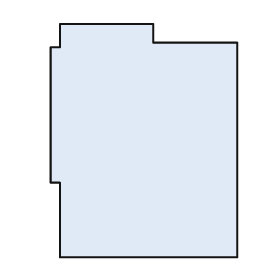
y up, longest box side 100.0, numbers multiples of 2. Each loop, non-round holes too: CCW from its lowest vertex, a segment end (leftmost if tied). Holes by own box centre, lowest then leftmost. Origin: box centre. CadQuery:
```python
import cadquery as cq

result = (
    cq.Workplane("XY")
    .moveTo(-36.0, -50.0)
    .lineTo(40.0, -50.0)
    .lineTo(40.0, 42.0)
    .lineTo(4.0, 42.0)
    .lineTo(4.0, 50.0)
    .lineTo(-36.0, 50.0)
    .lineTo(-36.0, 40.0)
    .lineTo(-40.0, 40.0)
    .lineTo(-40.0, -18.0)
    .lineTo(-36.0, -18.0)
    .close()
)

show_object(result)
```